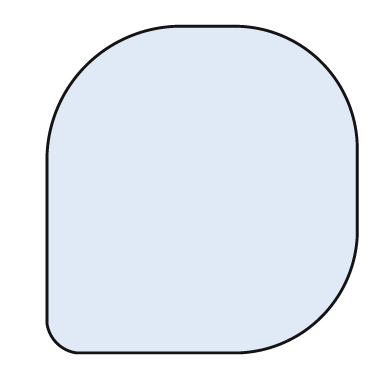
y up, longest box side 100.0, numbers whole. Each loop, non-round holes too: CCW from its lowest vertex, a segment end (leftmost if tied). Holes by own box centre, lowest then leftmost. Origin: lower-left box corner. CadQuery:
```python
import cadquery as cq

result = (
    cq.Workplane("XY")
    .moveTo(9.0, 0.0)
    .lineTo(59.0, 0.0)
    .threePointArc((84.0, 11.0), (95.0, 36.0))
    .lineTo(95.0, 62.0)
    .threePointArc((84.0, 89.0), (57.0, 100.0))
    .lineTo(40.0, 100.0)
    .threePointArc((12.0, 88.0), (0.0, 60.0))
    .lineTo(0.0, 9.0)
    .threePointArc((3.0, 3.0), (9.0, 0.0))
    .close()
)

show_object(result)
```